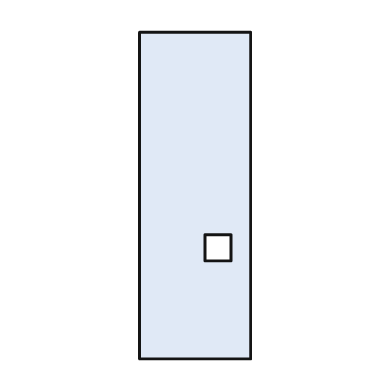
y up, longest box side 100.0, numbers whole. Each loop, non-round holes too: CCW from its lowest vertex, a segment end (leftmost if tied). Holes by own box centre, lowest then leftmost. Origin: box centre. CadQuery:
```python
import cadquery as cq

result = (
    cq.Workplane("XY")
    .moveTo(-17.0, -50.0)
    .lineTo(17.0, -50.0)
    .lineTo(17.0, 50.0)
    .lineTo(-17.0, 50.0)
    .close()
    .moveTo(3.0, -20.0)
    .lineTo(11.0, -20.0)
    .lineTo(11.0, -12.0)
    .lineTo(3.0, -12.0)
    .close()
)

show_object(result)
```